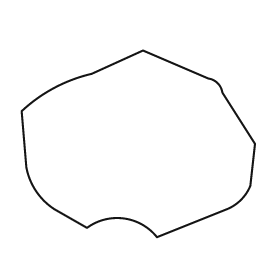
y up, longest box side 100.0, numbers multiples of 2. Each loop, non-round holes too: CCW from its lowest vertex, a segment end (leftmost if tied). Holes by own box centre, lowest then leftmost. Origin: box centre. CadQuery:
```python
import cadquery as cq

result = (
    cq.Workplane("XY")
    .moveTo(8.0, -40.0)
    .lineTo(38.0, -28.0)
    .threePointArc((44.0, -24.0), (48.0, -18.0))
    .lineTo(50.0, 0.0)
    .lineTo(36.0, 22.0)
    .threePointArc((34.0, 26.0), (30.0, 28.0))
    .lineTo(2.0, 40.0)
    .lineTo(-20.0, 30.0)
    .threePointArc((-36.0, 24.0), (-50.0, 14.0))
    .lineTo(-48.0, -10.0)
    .threePointArc((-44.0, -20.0), (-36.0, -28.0))
    .lineTo(-22.0, -36.0)
    .threePointArc((-6.0, -32.0), (8.0, -40.0))
    .close()
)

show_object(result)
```